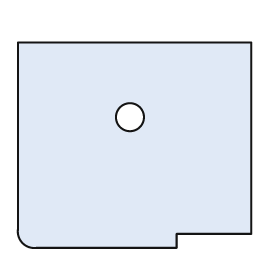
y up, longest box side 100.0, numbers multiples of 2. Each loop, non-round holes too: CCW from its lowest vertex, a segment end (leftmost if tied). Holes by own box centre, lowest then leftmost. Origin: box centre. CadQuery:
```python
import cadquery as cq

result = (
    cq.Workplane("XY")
    .moveTo(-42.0, -44.0)
    .lineTo(18.0, -44.0)
    .lineTo(18.0, -38.0)
    .lineTo(50.0, -38.0)
    .lineTo(50.0, 44.0)
    .lineTo(-50.0, 44.0)
    .lineTo(-50.0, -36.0)
    .threePointArc((-48.0, -42.0), (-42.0, -44.0))
    .close()
    .moveTo(-2.0, 12.0)
    .circle(6.0)
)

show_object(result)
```